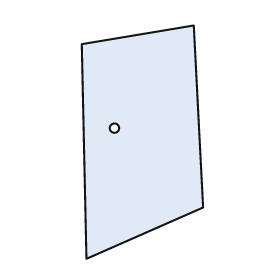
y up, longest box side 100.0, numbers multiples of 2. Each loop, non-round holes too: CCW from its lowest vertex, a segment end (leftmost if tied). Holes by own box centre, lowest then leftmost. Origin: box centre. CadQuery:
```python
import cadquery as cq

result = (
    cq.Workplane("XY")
    .moveTo(-24.0, -50.0)
    .lineTo(26.0, -28.0)
    .lineTo(22.0, 50.0)
    .lineTo(-26.0, 42.0)
    .close()
    .moveTo(-12.0, 6.0)
    .circle(2.0)
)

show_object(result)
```